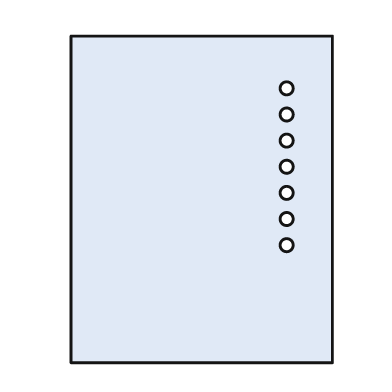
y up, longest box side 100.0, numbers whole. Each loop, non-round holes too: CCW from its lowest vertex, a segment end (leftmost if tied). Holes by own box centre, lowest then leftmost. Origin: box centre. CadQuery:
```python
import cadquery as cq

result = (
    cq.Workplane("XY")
    .moveTo(-40.0, -50.0)
    .lineTo(40.0, -50.0)
    .lineTo(40.0, 50.0)
    .lineTo(-40.0, 50.0)
    .close()
    .moveTo(26.0, -14.0)
    .circle(2.0)
    .moveTo(26.0, -6.0)
    .circle(2.0)
    .moveTo(26.0, 2.0)
    .circle(2.0)
    .moveTo(26.0, 10.0)
    .circle(2.0)
    .moveTo(26.0, 18.0)
    .circle(2.0)
    .moveTo(26.0, 26.0)
    .circle(2.0)
    .moveTo(26.0, 34.0)
    .circle(2.0)
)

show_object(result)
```